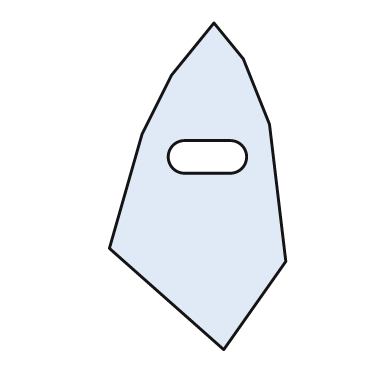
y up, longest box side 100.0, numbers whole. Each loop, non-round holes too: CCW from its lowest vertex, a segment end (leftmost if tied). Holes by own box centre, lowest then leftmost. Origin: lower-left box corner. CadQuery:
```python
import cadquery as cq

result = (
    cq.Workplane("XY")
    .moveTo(35.0, 0.0)
    .lineTo(54.0, 27.0)
    .lineTo(49.0, 69.0)
    .lineTo(41.0, 89.0)
    .lineTo(32.0, 100.0)
    .lineTo(19.0, 84.0)
    .lineTo(10.0, 66.0)
    .lineTo(0.0, 31.0)
    .close()
    .moveTo(23.0, 54.0)
    .lineTo(37.0, 54.0)
    .threePointArc((42.0, 59.0), (37.0, 64.0))
    .lineTo(23.0, 64.0)
    .threePointArc((18.0, 59.0), (23.0, 54.0))
    .close()
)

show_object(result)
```